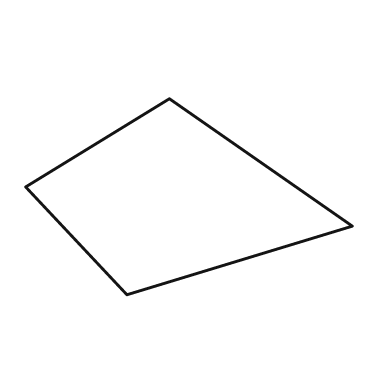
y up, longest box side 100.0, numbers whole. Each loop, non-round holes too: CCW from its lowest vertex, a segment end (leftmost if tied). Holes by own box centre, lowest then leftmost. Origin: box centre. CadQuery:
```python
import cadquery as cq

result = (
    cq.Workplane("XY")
    .moveTo(-19.0, -30.0)
    .lineTo(50.0, -9.0)
    .lineTo(-6.0, 30.0)
    .lineTo(-50.0, 3.0)
    .close()
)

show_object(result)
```